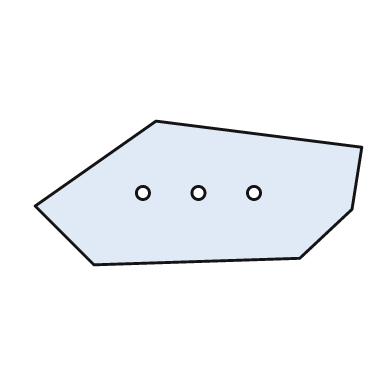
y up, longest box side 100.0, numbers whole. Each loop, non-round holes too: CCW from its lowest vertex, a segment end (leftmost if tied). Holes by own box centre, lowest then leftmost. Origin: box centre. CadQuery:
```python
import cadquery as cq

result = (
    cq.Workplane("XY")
    .moveTo(-32.0, -22.0)
    .lineTo(31.0, -20.0)
    .lineTo(47.0, -5.0)
    .lineTo(50.0, 14.0)
    .lineTo(-13.0, 22.0)
    .lineTo(-50.0, -4.0)
    .close()
    .moveTo(-17.0, 0.0)
    .circle(2.0)
    .moveTo(0.0, 0.0)
    .circle(2.0)
    .moveTo(17.0, 0.0)
    .circle(2.0)
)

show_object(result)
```